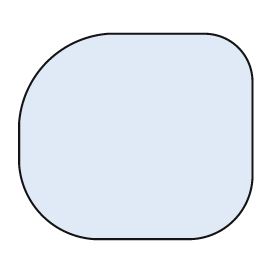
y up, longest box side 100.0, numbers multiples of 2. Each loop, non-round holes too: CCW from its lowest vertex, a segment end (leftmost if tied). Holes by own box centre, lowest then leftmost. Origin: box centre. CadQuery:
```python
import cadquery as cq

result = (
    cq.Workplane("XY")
    .moveTo(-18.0, -44.0)
    .lineTo(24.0, -44.0)
    .threePointArc((42.0, -36.0), (50.0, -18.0))
    .lineTo(50.0, 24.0)
    .threePointArc((44.0, 38.0), (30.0, 44.0))
    .lineTo(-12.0, 44.0)
    .threePointArc((-38.0, 32.0), (-50.0, 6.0))
    .lineTo(-50.0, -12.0)
    .threePointArc((-40.0, -34.0), (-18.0, -44.0))
    .close()
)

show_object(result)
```